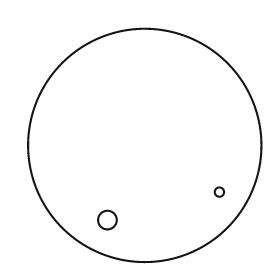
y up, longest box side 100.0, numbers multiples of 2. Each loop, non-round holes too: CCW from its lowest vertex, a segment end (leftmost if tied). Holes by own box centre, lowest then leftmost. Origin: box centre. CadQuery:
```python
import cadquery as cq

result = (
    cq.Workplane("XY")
    .moveTo(0.0, 0.0)
    .circle(50.0)
    .moveTo(-16.0, -32.0)
    .circle(4.0)
    .moveTo(32.0, -20.0)
    .circle(2.0)
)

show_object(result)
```